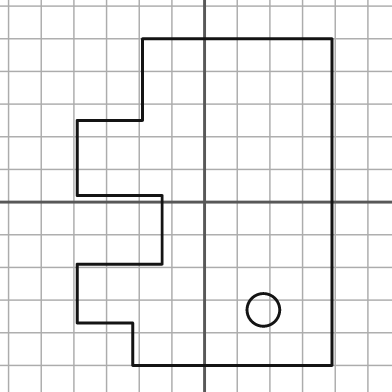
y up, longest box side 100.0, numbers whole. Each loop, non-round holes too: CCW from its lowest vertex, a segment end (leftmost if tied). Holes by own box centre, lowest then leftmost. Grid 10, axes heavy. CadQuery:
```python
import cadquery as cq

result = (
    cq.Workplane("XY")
    .moveTo(-22.0, -50.0)
    .lineTo(39.0, -50.0)
    .lineTo(39.0, 50.0)
    .lineTo(-19.0, 50.0)
    .lineTo(-19.0, 25.0)
    .lineTo(-39.0, 25.0)
    .lineTo(-39.0, 2.0)
    .lineTo(-13.0, 2.0)
    .lineTo(-13.0, -19.0)
    .lineTo(-39.0, -19.0)
    .lineTo(-39.0, -37.0)
    .lineTo(-22.0, -37.0)
    .close()
    .moveTo(18.0, -33.0)
    .circle(5.0)
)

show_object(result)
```